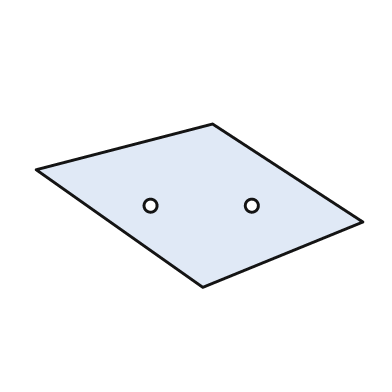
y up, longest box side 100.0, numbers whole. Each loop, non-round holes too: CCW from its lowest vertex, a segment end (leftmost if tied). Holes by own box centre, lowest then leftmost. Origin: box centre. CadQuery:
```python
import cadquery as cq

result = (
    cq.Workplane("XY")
    .moveTo(1.0, -25.0)
    .lineTo(50.0, -5.0)
    .lineTo(4.0, 25.0)
    .lineTo(-50.0, 11.0)
    .close()
    .moveTo(-15.0, 0.0)
    .circle(2.0)
    .moveTo(16.0, 0.0)
    .circle(2.0)
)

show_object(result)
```